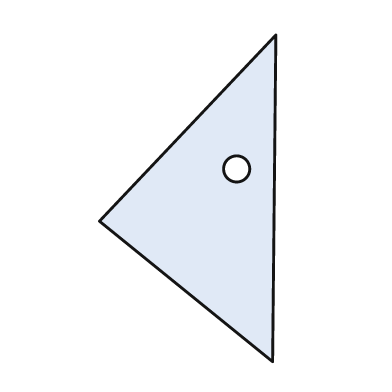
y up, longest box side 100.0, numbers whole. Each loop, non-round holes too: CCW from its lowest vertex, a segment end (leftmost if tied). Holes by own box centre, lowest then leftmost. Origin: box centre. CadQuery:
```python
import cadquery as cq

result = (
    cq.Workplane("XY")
    .moveTo(26.0, -50.0)
    .lineTo(27.0, 50.0)
    .lineTo(-27.0, -7.0)
    .close()
    .moveTo(15.0, 9.0)
    .circle(4.0)
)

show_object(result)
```